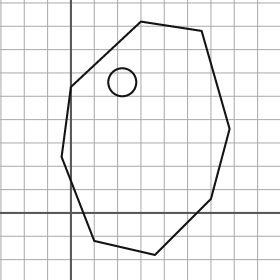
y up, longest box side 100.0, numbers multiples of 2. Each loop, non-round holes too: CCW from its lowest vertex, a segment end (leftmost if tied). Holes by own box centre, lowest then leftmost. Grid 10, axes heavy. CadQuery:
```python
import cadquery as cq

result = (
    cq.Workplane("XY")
    .moveTo(36.0, -18.0)
    .lineTo(60.0, 6.0)
    .lineTo(68.0, 36.0)
    .lineTo(56.0, 78.0)
    .lineTo(30.0, 82.0)
    .lineTo(0.0, 54.0)
    .lineTo(-4.0, 24.0)
    .lineTo(10.0, -12.0)
    .close()
    .moveTo(22.0, 56.0)
    .circle(6.0)
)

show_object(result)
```